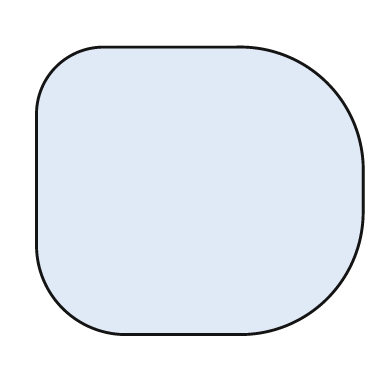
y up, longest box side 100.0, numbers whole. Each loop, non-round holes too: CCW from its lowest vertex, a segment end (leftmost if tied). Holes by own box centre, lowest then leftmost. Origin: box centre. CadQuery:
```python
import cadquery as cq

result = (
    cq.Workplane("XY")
    .moveTo(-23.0, -44.0)
    .lineTo(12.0, -44.0)
    .threePointArc((39.0, -33.0), (50.0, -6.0))
    .lineTo(50.0, 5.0)
    .threePointArc((39.0, 33.0), (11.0, 44.0))
    .lineTo(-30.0, 44.0)
    .threePointArc((-44.0, 38.0), (-50.0, 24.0))
    .lineTo(-50.0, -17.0)
    .threePointArc((-42.0, -36.0), (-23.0, -44.0))
    .close()
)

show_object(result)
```